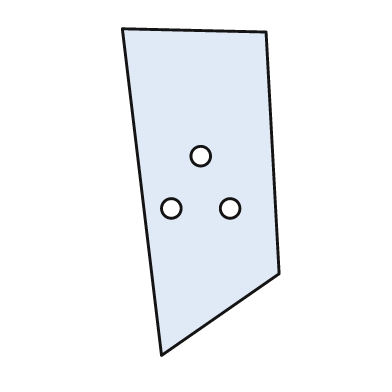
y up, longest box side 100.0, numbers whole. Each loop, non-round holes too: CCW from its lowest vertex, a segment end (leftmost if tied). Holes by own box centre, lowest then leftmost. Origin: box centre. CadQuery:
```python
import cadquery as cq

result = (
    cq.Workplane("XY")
    .moveTo(-12.0, -50.0)
    .lineTo(24.0, -25.0)
    .lineTo(20.0, 49.0)
    .lineTo(-24.0, 50.0)
    .close()
    .moveTo(-9.0, -5.0)
    .circle(3.0)
    .moveTo(9.0, -5.0)
    .circle(3.0)
    .moveTo(0.0, 11.0)
    .circle(3.0)
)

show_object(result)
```